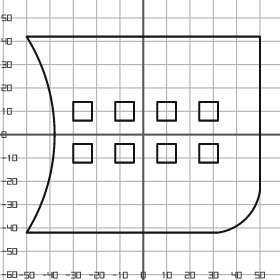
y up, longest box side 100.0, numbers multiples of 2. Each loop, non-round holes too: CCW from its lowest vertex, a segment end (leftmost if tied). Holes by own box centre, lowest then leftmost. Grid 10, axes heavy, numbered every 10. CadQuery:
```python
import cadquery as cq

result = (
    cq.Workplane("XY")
    .moveTo(-50.0, -42.0)
    .lineTo(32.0, -42.0)
    .threePointArc((44.0, -36.0), (50.0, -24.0))
    .lineTo(50.0, 42.0)
    .lineTo(-50.0, 42.0)
    .threePointArc((-38.0, 0.0), (-50.0, -42.0))
    .close()
    .moveTo(-30.0, -12.0)
    .lineTo(-22.0, -12.0)
    .lineTo(-22.0, -4.0)
    .lineTo(-30.0, -4.0)
    .close()
    .moveTo(-12.0, -12.0)
    .lineTo(-4.0, -12.0)
    .lineTo(-4.0, -4.0)
    .lineTo(-12.0, -4.0)
    .close()
    .moveTo(6.0, -12.0)
    .lineTo(14.0, -12.0)
    .lineTo(14.0, -4.0)
    .lineTo(6.0, -4.0)
    .close()
    .moveTo(24.0, -12.0)
    .lineTo(32.0, -12.0)
    .lineTo(32.0, -4.0)
    .lineTo(24.0, -4.0)
    .close()
    .moveTo(-30.0, 6.0)
    .lineTo(-22.0, 6.0)
    .lineTo(-22.0, 14.0)
    .lineTo(-30.0, 14.0)
    .close()
    .moveTo(-12.0, 6.0)
    .lineTo(-4.0, 6.0)
    .lineTo(-4.0, 14.0)
    .lineTo(-12.0, 14.0)
    .close()
    .moveTo(6.0, 6.0)
    .lineTo(14.0, 6.0)
    .lineTo(14.0, 14.0)
    .lineTo(6.0, 14.0)
    .close()
    .moveTo(24.0, 6.0)
    .lineTo(32.0, 6.0)
    .lineTo(32.0, 14.0)
    .lineTo(24.0, 14.0)
    .close()
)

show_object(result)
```